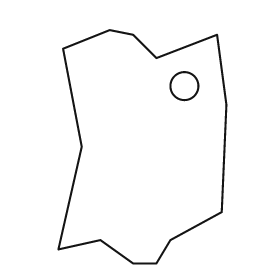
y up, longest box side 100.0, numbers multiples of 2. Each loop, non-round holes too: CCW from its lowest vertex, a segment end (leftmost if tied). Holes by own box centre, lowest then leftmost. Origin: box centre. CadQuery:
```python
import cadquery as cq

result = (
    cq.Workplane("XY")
    .moveTo(-4.0, -50.0)
    .lineTo(6.0, -50.0)
    .lineTo(12.0, -40.0)
    .lineTo(34.0, -28.0)
    .lineTo(36.0, 18.0)
    .lineTo(32.0, 48.0)
    .lineTo(6.0, 38.0)
    .lineTo(-4.0, 48.0)
    .lineTo(-14.0, 50.0)
    .lineTo(-34.0, 42.0)
    .lineTo(-26.0, 0.0)
    .lineTo(-36.0, -44.0)
    .lineTo(-18.0, -40.0)
    .close()
    .moveTo(18.0, 26.0)
    .circle(6.0)
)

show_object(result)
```